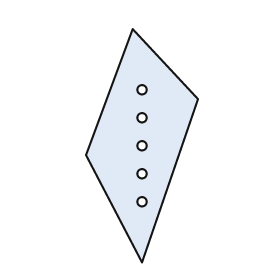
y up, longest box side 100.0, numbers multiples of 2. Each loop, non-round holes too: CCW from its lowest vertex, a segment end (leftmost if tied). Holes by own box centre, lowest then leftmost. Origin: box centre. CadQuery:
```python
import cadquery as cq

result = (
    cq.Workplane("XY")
    .moveTo(0.0, -50.0)
    .lineTo(24.0, 20.0)
    .lineTo(-4.0, 50.0)
    .lineTo(-24.0, -4.0)
    .close()
    .moveTo(0.0, -24.0)
    .circle(2.0)
    .moveTo(0.0, -12.0)
    .circle(2.0)
    .moveTo(0.0, 0.0)
    .circle(2.0)
    .moveTo(0.0, 12.0)
    .circle(2.0)
    .moveTo(0.0, 24.0)
    .circle(2.0)
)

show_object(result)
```